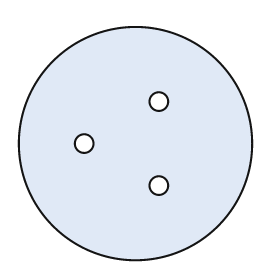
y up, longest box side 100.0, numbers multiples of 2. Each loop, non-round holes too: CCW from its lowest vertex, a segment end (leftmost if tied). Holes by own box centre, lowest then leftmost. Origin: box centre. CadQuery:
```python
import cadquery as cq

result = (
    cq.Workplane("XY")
    .moveTo(0.0, 0.0)
    .circle(50.0)
    .moveTo(10.0, -18.0)
    .circle(4.0)
    .moveTo(-22.0, 0.0)
    .circle(4.0)
    .moveTo(10.0, 18.0)
    .circle(4.0)
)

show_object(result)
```